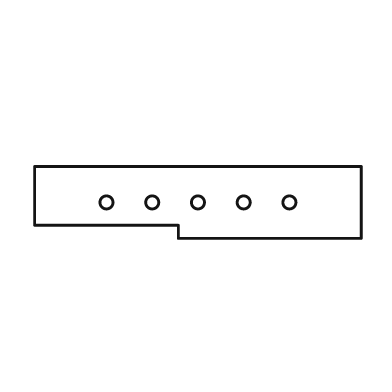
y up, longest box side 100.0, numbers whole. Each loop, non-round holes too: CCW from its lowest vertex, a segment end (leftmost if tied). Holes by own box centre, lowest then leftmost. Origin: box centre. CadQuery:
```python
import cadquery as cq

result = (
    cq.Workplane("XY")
    .moveTo(-6.0, -11.0)
    .lineTo(50.0, -11.0)
    .lineTo(50.0, 11.0)
    .lineTo(-50.0, 11.0)
    .lineTo(-50.0, -7.0)
    .lineTo(-6.0, -7.0)
    .close()
    .moveTo(-28.0, 0.0)
    .circle(2.0)
    .moveTo(-14.0, 0.0)
    .circle(2.0)
    .moveTo(0.0, 0.0)
    .circle(2.0)
    .moveTo(14.0, 0.0)
    .circle(2.0)
    .moveTo(28.0, 0.0)
    .circle(2.0)
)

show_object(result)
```